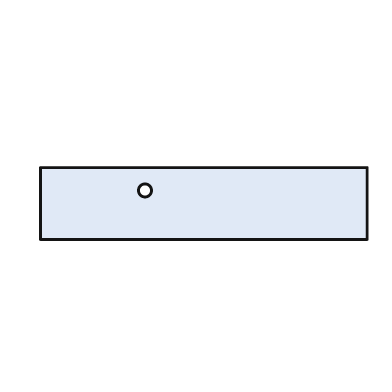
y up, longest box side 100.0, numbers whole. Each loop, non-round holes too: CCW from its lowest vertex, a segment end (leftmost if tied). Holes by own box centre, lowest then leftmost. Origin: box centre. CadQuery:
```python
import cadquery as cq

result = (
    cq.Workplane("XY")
    .moveTo(-50.0, -11.0)
    .lineTo(50.0, -11.0)
    .lineTo(50.0, 11.0)
    .lineTo(-50.0, 11.0)
    .close()
    .moveTo(-18.0, 4.0)
    .circle(2.0)
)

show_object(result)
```